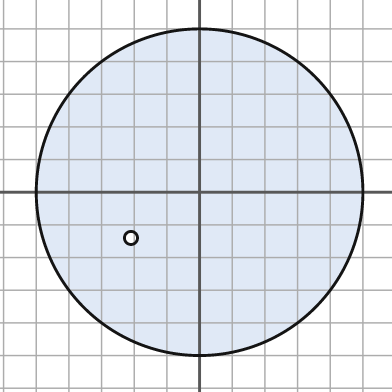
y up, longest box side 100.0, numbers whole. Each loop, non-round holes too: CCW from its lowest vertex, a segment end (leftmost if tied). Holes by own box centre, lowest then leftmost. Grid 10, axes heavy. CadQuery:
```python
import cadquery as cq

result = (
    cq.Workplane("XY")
    .moveTo(0.0, 0.0)
    .circle(50.0)
    .moveTo(-21.0, -14.0)
    .circle(2.0)
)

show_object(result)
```